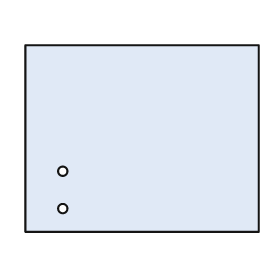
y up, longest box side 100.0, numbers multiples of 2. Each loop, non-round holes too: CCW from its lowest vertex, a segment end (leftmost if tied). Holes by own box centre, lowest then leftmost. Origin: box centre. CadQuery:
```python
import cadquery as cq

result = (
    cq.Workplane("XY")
    .moveTo(-50.0, -40.0)
    .lineTo(50.0, -40.0)
    .lineTo(50.0, 40.0)
    .lineTo(-50.0, 40.0)
    .close()
    .moveTo(-34.0, -30.0)
    .circle(2.0)
    .moveTo(-34.0, -14.0)
    .circle(2.0)
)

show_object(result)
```